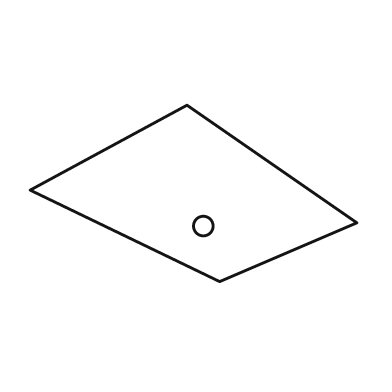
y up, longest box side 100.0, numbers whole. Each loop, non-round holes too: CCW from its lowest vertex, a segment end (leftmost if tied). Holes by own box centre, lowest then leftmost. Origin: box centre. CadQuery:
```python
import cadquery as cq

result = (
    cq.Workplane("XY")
    .moveTo(8.0, -27.0)
    .lineTo(50.0, -9.0)
    .lineTo(-2.0, 27.0)
    .lineTo(-50.0, 1.0)
    .close()
    .moveTo(3.0, -10.0)
    .circle(3.0)
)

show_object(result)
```